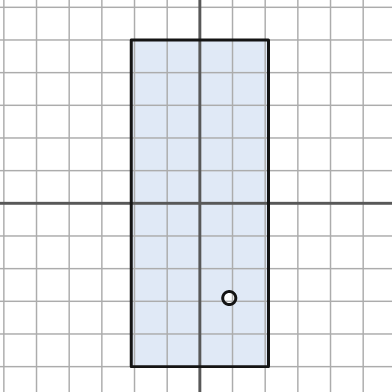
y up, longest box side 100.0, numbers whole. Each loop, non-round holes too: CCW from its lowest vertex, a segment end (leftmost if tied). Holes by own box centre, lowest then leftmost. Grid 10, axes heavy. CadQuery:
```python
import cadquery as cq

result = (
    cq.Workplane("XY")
    .moveTo(-21.0, -50.0)
    .lineTo(21.0, -50.0)
    .lineTo(21.0, 50.0)
    .lineTo(-21.0, 50.0)
    .close()
    .moveTo(9.0, -29.0)
    .circle(2.0)
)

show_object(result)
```